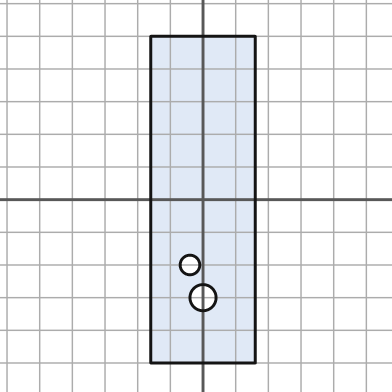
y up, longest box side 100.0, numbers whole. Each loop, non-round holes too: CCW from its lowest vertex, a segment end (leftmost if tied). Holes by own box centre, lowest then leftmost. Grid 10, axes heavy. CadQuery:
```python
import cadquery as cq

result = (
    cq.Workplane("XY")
    .moveTo(-16.0, -50.0)
    .lineTo(16.0, -50.0)
    .lineTo(16.0, 50.0)
    .lineTo(-16.0, 50.0)
    .close()
    .moveTo(0.0, -30.0)
    .circle(4.0)
    .moveTo(-4.0, -20.0)
    .circle(3.0)
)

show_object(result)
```